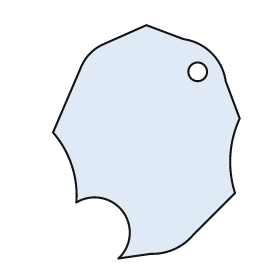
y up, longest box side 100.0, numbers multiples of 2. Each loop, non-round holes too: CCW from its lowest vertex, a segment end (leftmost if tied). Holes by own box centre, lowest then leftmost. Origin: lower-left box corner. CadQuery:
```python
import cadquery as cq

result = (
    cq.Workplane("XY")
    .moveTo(28.0, 0.0)
    .lineTo(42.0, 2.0)
    .threePointArc((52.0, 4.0), (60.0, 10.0))
    .lineTo(78.0, 28.0)
    .threePointArc((76.0, 44.0), (80.0, 60.0))
    .lineTo(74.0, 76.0)
    .threePointArc((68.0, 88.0), (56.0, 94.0))
    .lineTo(40.0, 100.0)
    .lineTo(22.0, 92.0)
    .threePointArc((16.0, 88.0), (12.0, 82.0))
    .lineTo(0.0, 54.0)
    .threePointArc((8.0, 40.0), (10.0, 24.0))
    .threePointArc((30.0, 20.0), (28.0, 0.0))
    .close()
    .moveTo(62.0, 80.0)
    .circle(4.0)
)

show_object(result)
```